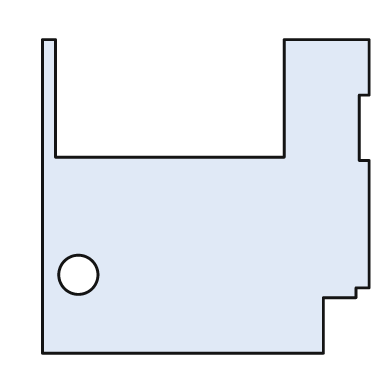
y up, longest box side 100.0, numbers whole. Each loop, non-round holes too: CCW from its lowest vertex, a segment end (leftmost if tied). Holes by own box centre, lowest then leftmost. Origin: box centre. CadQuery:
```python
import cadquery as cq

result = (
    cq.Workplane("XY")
    .moveTo(-50.0, -48.0)
    .lineTo(36.0, -48.0)
    .lineTo(36.0, -31.0)
    .lineTo(46.0, -31.0)
    .lineTo(46.0, -28.0)
    .lineTo(50.0, -28.0)
    .lineTo(50.0, 11.0)
    .lineTo(47.0, 11.0)
    .lineTo(47.0, 31.0)
    .lineTo(50.0, 31.0)
    .lineTo(50.0, 48.0)
    .lineTo(24.0, 48.0)
    .lineTo(24.0, 12.0)
    .lineTo(-46.0, 12.0)
    .lineTo(-46.0, 48.0)
    .lineTo(-50.0, 48.0)
    .close()
    .moveTo(-39.0, -24.0)
    .circle(6.0)
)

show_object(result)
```